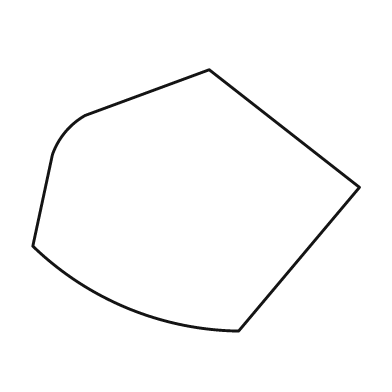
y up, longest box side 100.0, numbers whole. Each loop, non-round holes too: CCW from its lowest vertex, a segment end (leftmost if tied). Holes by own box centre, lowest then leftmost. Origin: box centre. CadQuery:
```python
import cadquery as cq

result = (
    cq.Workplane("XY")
    .moveTo(13.0, -40.0)
    .lineTo(50.0, 4.0)
    .lineTo(4.0, 40.0)
    .lineTo(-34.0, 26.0)
    .threePointArc((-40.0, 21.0), (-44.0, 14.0))
    .lineTo(-50.0, -14.0)
    .threePointArc((-21.0, -33.0), (13.0, -40.0))
    .close()
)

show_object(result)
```